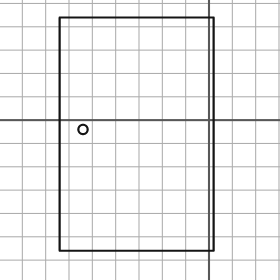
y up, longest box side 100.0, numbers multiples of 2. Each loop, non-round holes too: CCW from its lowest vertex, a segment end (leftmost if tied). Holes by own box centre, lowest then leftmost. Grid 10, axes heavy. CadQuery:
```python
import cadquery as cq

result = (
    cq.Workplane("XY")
    .moveTo(-64.0, -56.0)
    .lineTo(2.0, -56.0)
    .lineTo(2.0, 44.0)
    .lineTo(-64.0, 44.0)
    .close()
    .moveTo(-54.0, -4.0)
    .circle(2.0)
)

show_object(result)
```